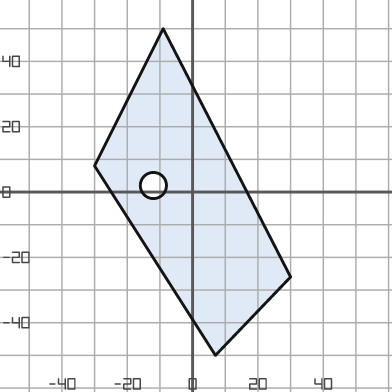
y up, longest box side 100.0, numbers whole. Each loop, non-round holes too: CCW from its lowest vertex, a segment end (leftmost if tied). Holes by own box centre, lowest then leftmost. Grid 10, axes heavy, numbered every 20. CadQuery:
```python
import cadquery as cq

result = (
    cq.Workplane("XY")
    .moveTo(7.0, -50.0)
    .lineTo(30.0, -26.0)
    .lineTo(-9.0, 50.0)
    .lineTo(-30.0, 8.0)
    .close()
    .moveTo(-12.0, 2.0)
    .circle(4.0)
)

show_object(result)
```